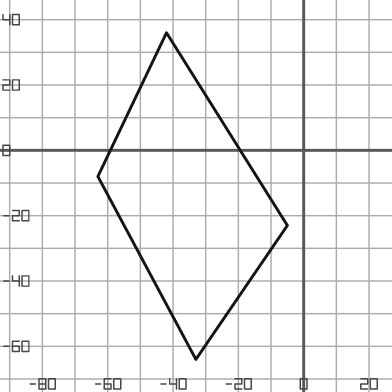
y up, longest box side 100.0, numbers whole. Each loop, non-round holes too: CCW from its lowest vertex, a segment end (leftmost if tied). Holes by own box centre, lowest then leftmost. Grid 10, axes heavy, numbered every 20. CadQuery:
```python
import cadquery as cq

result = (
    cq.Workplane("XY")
    .moveTo(-33.0, -64.0)
    .lineTo(-5.0, -23.0)
    .lineTo(-42.0, 36.0)
    .lineTo(-63.0, -8.0)
    .close()
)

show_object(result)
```